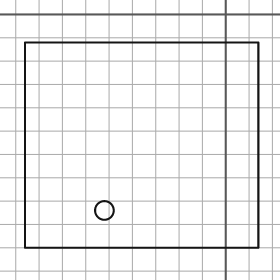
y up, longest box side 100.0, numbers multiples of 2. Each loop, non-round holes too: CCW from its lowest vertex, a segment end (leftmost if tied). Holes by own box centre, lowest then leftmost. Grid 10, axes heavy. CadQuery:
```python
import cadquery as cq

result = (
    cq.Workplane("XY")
    .moveTo(-86.0, -100.0)
    .lineTo(14.0, -100.0)
    .lineTo(14.0, -12.0)
    .lineTo(-86.0, -12.0)
    .close()
    .moveTo(-52.0, -84.0)
    .circle(4.0)
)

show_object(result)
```